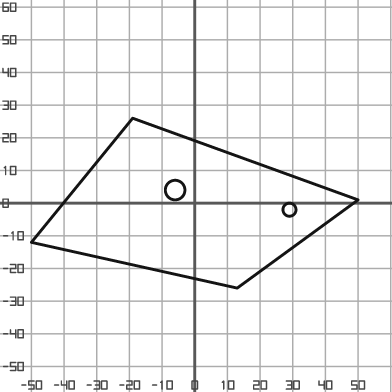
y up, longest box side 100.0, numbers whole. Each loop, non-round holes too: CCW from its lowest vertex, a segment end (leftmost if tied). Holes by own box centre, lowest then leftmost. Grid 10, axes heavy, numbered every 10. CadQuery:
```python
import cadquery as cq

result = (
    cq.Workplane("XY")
    .moveTo(13.0, -26.0)
    .lineTo(50.0, 1.0)
    .lineTo(-19.0, 26.0)
    .lineTo(-50.0, -12.0)
    .close()
    .moveTo(29.0, -2.0)
    .circle(2.0)
    .moveTo(-6.0, 4.0)
    .circle(3.0)
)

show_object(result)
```